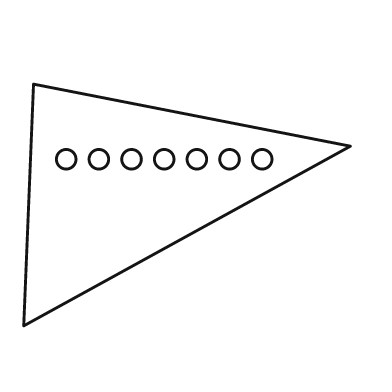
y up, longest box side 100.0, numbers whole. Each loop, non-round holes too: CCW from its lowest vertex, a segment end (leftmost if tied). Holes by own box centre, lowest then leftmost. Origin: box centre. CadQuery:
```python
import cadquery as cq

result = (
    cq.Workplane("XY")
    .moveTo(-50.0, -37.0)
    .lineTo(50.0, 18.0)
    .lineTo(-47.0, 37.0)
    .close()
    .moveTo(-37.0, 14.0)
    .circle(3.0)
    .moveTo(-27.0, 14.0)
    .circle(3.0)
    .moveTo(-17.0, 14.0)
    .circle(3.0)
    .moveTo(-7.0, 14.0)
    .circle(3.0)
    .moveTo(3.0, 14.0)
    .circle(3.0)
    .moveTo(13.0, 14.0)
    .circle(3.0)
    .moveTo(23.0, 14.0)
    .circle(3.0)
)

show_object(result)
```